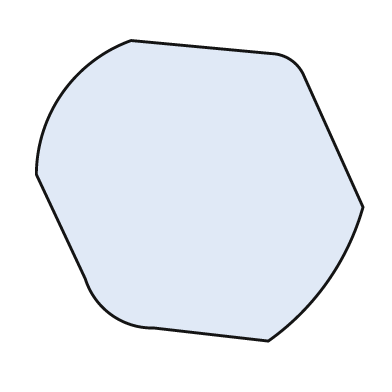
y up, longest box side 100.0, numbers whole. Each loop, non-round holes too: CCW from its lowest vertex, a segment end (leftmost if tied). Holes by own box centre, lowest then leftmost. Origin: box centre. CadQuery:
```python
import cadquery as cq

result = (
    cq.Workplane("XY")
    .moveTo(21.0, -46.0)
    .threePointArc((39.0, -28.0), (50.0, -5.0))
    .lineTo(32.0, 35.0)
    .threePointArc((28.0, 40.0), (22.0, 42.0))
    .lineTo(-21.0, 46.0)
    .threePointArc((-42.0, 30.0), (-50.0, 5.0))
    .lineTo(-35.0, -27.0)
    .threePointArc((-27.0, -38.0), (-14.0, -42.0))
    .close()
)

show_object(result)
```